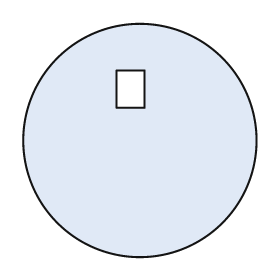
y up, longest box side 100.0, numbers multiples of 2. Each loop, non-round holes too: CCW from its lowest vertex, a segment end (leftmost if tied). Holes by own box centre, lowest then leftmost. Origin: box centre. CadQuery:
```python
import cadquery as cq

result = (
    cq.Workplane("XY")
    .moveTo(0.0, 0.0)
    .circle(50.0)
    .moveTo(-10.0, 14.0)
    .lineTo(2.0, 14.0)
    .lineTo(2.0, 30.0)
    .lineTo(-10.0, 30.0)
    .close()
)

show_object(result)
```